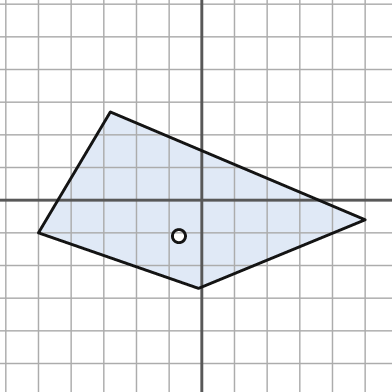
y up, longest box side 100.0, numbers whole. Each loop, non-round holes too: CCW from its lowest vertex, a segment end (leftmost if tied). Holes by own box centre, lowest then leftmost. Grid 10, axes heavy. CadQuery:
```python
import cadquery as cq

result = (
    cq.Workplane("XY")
    .moveTo(-1.0, -27.0)
    .lineTo(50.0, -6.0)
    .lineTo(-28.0, 27.0)
    .lineTo(-50.0, -10.0)
    .close()
    .moveTo(-7.0, -11.0)
    .circle(2.0)
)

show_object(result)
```